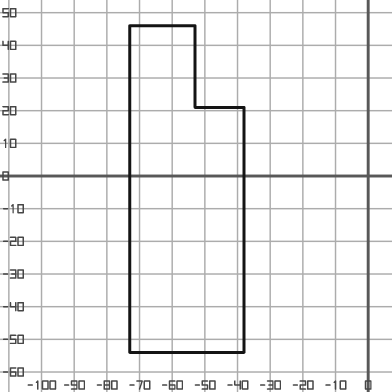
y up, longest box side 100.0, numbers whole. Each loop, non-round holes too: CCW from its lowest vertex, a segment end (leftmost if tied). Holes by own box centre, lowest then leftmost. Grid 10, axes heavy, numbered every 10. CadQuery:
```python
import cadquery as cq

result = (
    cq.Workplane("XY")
    .moveTo(-73.0, -54.0)
    .lineTo(-38.0, -54.0)
    .lineTo(-38.0, 21.0)
    .lineTo(-53.0, 21.0)
    .lineTo(-53.0, 46.0)
    .lineTo(-73.0, 46.0)
    .close()
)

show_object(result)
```